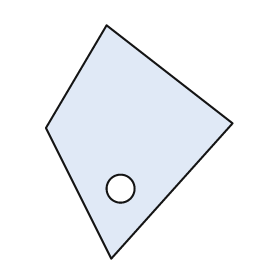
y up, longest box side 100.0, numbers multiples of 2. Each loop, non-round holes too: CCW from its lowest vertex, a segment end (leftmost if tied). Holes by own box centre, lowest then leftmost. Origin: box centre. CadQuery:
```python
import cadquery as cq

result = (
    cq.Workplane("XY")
    .moveTo(-12.0, -50.0)
    .lineTo(40.0, 8.0)
    .lineTo(-14.0, 50.0)
    .lineTo(-40.0, 6.0)
    .close()
    .moveTo(-8.0, -20.0)
    .circle(6.0)
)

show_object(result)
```